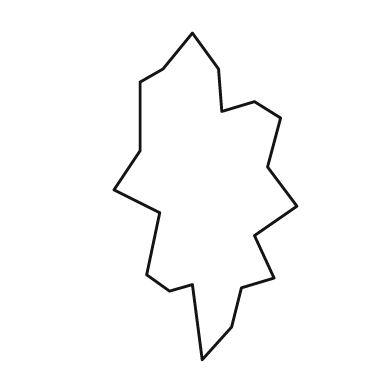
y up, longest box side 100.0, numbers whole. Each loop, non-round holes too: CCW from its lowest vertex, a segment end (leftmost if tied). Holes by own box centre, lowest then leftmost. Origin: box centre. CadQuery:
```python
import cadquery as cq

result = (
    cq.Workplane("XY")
    .moveTo(-1.0, -50.0)
    .lineTo(8.0, -40.0)
    .lineTo(11.0, -28.0)
    .lineTo(21.0, -25.0)
    .lineTo(15.0, -12.0)
    .lineTo(28.0, -3.0)
    .lineTo(19.0, 9.0)
    .lineTo(23.0, 24.0)
    .lineTo(15.0, 29.0)
    .lineTo(5.0, 26.0)
    .lineTo(4.0, 39.0)
    .lineTo(-4.0, 50.0)
    .lineTo(-13.0, 39.0)
    .lineTo(-20.0, 35.0)
    .lineTo(-20.0, 14.0)
    .lineTo(-28.0, 2.0)
    .lineTo(-14.0, -5.0)
    .lineTo(-18.0, -24.0)
    .lineTo(-11.0, -29.0)
    .lineTo(-4.0, -27.0)
    .close()
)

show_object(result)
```